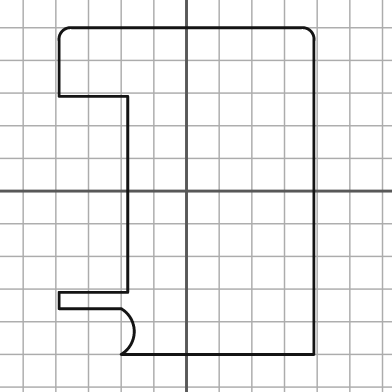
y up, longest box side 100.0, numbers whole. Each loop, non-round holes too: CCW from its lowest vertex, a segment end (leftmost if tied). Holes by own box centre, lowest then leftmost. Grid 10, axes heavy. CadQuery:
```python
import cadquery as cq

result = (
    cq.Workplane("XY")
    .moveTo(-20.0, -50.0)
    .lineTo(39.0, -50.0)
    .lineTo(39.0, 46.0)
    .threePointArc((38.0, 49.0), (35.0, 50.0))
    .lineTo(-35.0, 50.0)
    .threePointArc((-38.0, 49.0), (-39.0, 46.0))
    .lineTo(-39.0, 29.0)
    .lineTo(-18.0, 29.0)
    .lineTo(-18.0, -31.0)
    .lineTo(-39.0, -31.0)
    .lineTo(-39.0, -36.0)
    .lineTo(-20.0, -36.0)
    .threePointArc((-16.0, -43.0), (-20.0, -50.0))
    .close()
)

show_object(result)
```